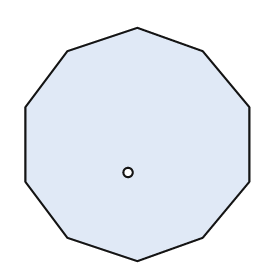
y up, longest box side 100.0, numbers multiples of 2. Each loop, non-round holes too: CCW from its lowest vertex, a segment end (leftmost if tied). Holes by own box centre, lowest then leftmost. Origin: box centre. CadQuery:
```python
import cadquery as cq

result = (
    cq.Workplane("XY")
    .moveTo(0.0, -50.0)
    .lineTo(28.0, -40.0)
    .lineTo(48.0, -16.0)
    .lineTo(48.0, 16.0)
    .lineTo(28.0, 40.0)
    .lineTo(0.0, 50.0)
    .lineTo(-30.0, 40.0)
    .lineTo(-48.0, 16.0)
    .lineTo(-48.0, -16.0)
    .lineTo(-30.0, -40.0)
    .close()
    .moveTo(-4.0, -12.0)
    .circle(2.0)
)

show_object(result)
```